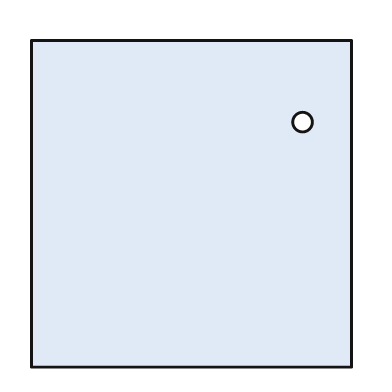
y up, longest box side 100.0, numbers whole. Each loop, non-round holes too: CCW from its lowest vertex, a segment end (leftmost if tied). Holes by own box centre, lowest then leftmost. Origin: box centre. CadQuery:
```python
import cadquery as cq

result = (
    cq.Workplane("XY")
    .moveTo(-49.0, -50.0)
    .lineTo(49.0, -50.0)
    .lineTo(49.0, 50.0)
    .lineTo(-49.0, 50.0)
    .close()
    .moveTo(34.0, 25.0)
    .circle(3.0)
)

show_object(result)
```